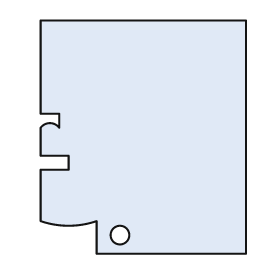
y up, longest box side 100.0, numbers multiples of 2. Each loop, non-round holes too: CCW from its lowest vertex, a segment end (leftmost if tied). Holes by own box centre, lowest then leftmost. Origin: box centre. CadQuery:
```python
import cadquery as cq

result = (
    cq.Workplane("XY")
    .moveTo(-20.0, -50.0)
    .lineTo(44.0, -50.0)
    .lineTo(44.0, 50.0)
    .lineTo(-44.0, 50.0)
    .lineTo(-44.0, 10.0)
    .lineTo(-36.0, 10.0)
    .lineTo(-36.0, 4.0)
    .threePointArc((-40.0, 6.0), (-44.0, 4.0))
    .lineTo(-44.0, -8.0)
    .lineTo(-32.0, -8.0)
    .lineTo(-32.0, -14.0)
    .lineTo(-44.0, -14.0)
    .lineTo(-44.0, -36.0)
    .threePointArc((-32.0, -38.0), (-20.0, -36.0))
    .close()
    .moveTo(-10.0, -42.0)
    .circle(4.0)
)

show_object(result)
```